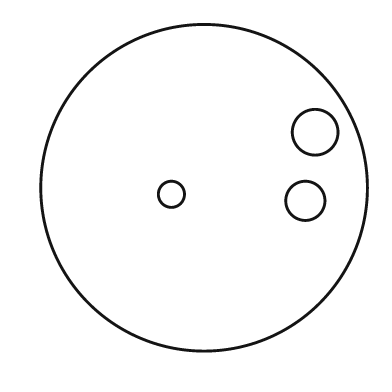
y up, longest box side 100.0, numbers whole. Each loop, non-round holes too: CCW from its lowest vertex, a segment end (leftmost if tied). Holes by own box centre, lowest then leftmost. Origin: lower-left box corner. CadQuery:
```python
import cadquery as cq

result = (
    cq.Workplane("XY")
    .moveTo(50.0, 50.0)
    .circle(50.0)
    .moveTo(81.0, 46.0)
    .circle(6.0)
    .moveTo(40.0, 48.0)
    .circle(4.0)
    .moveTo(84.0, 67.0)
    .circle(7.0)
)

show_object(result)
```